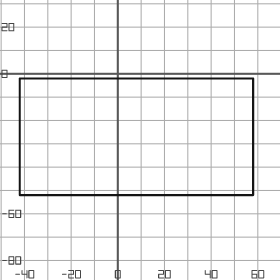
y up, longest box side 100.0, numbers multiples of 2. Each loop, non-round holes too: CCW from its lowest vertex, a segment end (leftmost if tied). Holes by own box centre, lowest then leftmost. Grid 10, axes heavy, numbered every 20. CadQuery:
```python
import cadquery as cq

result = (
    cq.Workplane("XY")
    .moveTo(-42.0, -52.0)
    .lineTo(58.0, -52.0)
    .lineTo(58.0, -2.0)
    .lineTo(-42.0, -2.0)
    .close()
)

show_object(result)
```